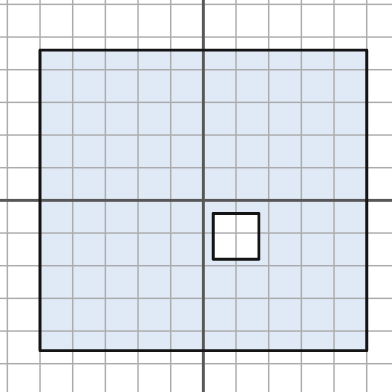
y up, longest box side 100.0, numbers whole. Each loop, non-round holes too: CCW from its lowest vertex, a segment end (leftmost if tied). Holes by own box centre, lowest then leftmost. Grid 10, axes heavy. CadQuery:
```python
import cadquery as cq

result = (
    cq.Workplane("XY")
    .moveTo(-50.0, -46.0)
    .lineTo(50.0, -46.0)
    .lineTo(50.0, 46.0)
    .lineTo(-50.0, 46.0)
    .close()
    .moveTo(3.0, -18.0)
    .lineTo(17.0, -18.0)
    .lineTo(17.0, -4.0)
    .lineTo(3.0, -4.0)
    .close()
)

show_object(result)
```